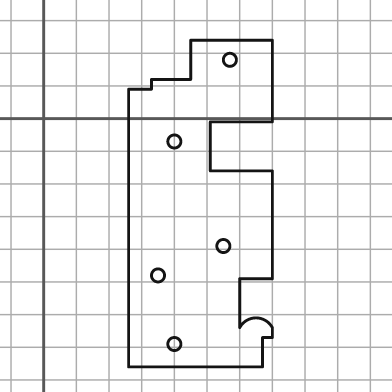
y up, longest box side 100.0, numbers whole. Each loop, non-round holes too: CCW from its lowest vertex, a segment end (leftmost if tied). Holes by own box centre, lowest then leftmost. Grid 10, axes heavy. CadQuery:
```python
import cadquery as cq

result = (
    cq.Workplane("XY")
    .moveTo(26.0, -76.0)
    .lineTo(67.0, -76.0)
    .lineTo(67.0, -67.0)
    .lineTo(70.0, -67.0)
    .lineTo(70.0, -64.0)
    .threePointArc((65.0, -61.0), (60.0, -64.0))
    .lineTo(60.0, -49.0)
    .lineTo(70.0, -49.0)
    .lineTo(70.0, -16.0)
    .lineTo(51.0, -16.0)
    .lineTo(51.0, -1.0)
    .lineTo(70.0, -1.0)
    .lineTo(70.0, 24.0)
    .lineTo(45.0, 24.0)
    .lineTo(45.0, 12.0)
    .lineTo(33.0, 12.0)
    .lineTo(33.0, 9.0)
    .lineTo(26.0, 9.0)
    .close()
    .moveTo(40.0, -69.0)
    .circle(2.0)
    .moveTo(35.0, -48.0)
    .circle(2.0)
    .moveTo(55.0, -39.0)
    .circle(2.0)
    .moveTo(40.0, -7.0)
    .circle(2.0)
    .moveTo(57.0, 18.0)
    .circle(2.0)
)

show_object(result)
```